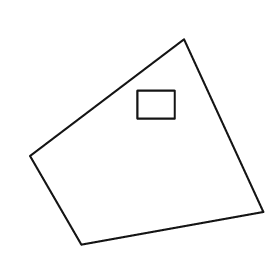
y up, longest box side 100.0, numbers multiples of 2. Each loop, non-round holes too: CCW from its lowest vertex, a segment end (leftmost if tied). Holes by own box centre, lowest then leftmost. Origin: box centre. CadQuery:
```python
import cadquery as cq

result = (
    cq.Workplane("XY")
    .moveTo(-28.0, -44.0)
    .lineTo(50.0, -30.0)
    .lineTo(16.0, 44.0)
    .lineTo(-50.0, -6.0)
    .close()
    .moveTo(-4.0, 10.0)
    .lineTo(12.0, 10.0)
    .lineTo(12.0, 22.0)
    .lineTo(-4.0, 22.0)
    .close()
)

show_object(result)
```